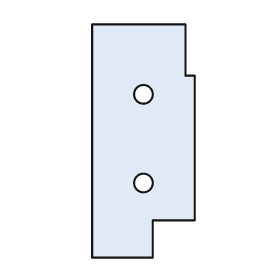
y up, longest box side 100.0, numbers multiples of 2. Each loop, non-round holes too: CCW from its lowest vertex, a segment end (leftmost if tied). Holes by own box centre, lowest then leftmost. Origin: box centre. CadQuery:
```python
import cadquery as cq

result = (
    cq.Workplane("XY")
    .moveTo(-22.0, -50.0)
    .lineTo(4.0, -50.0)
    .lineTo(4.0, -34.0)
    .lineTo(22.0, -34.0)
    .lineTo(22.0, 28.0)
    .lineTo(18.0, 28.0)
    .lineTo(18.0, 50.0)
    .lineTo(-22.0, 50.0)
    .close()
    .moveTo(0.0, -18.0)
    .circle(4.0)
    .moveTo(0.0, 20.0)
    .circle(4.0)
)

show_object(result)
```